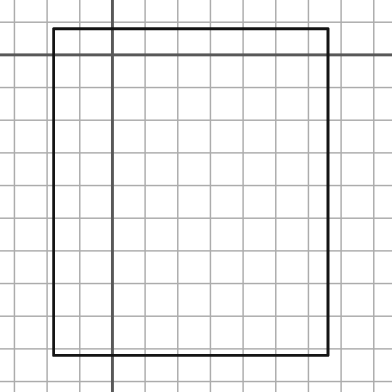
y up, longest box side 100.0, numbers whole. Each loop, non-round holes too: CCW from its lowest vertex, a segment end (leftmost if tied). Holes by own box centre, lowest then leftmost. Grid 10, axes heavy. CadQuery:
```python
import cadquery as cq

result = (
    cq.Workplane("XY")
    .moveTo(-18.0, -92.0)
    .lineTo(66.0, -92.0)
    .lineTo(66.0, 8.0)
    .lineTo(-18.0, 8.0)
    .close()
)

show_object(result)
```